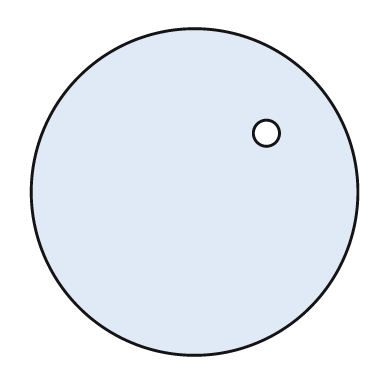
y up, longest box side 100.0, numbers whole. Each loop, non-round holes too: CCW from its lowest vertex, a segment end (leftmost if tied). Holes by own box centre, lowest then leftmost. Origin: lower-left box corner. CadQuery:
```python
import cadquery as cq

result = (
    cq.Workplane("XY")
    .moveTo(50.0, 50.0)
    .circle(50.0)
    .moveTo(72.0, 68.0)
    .circle(4.0)
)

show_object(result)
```